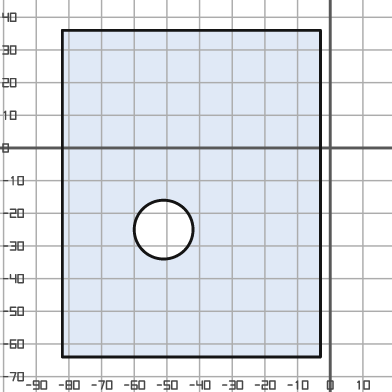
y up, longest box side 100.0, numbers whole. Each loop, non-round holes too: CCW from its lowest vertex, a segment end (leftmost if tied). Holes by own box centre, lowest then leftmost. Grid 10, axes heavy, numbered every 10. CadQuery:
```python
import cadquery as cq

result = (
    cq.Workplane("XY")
    .moveTo(-82.0, -64.0)
    .lineTo(-3.0, -64.0)
    .lineTo(-3.0, 36.0)
    .lineTo(-82.0, 36.0)
    .close()
    .moveTo(-51.0, -25.0)
    .circle(9.0)
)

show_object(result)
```